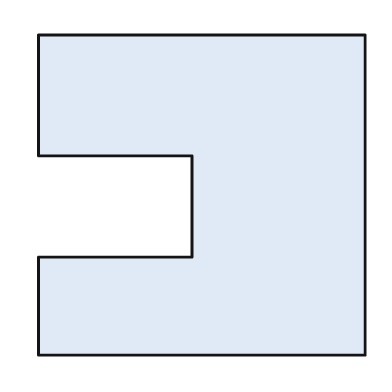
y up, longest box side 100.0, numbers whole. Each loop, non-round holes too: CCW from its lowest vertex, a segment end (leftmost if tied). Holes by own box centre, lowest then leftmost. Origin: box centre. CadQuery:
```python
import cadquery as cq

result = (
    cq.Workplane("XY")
    .moveTo(-50.0, -49.0)
    .lineTo(50.0, -49.0)
    .lineTo(50.0, 49.0)
    .lineTo(-50.0, 49.0)
    .lineTo(-50.0, 12.0)
    .lineTo(-3.0, 12.0)
    .lineTo(-3.0, -19.0)
    .lineTo(-50.0, -19.0)
    .close()
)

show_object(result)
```